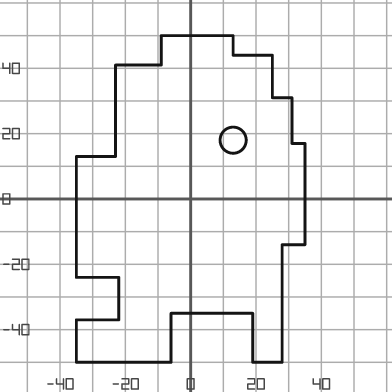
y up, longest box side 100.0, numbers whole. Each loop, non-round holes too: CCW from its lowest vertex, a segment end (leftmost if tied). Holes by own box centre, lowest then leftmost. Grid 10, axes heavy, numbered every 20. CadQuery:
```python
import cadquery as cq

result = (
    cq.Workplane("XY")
    .moveTo(-35.0, -50.0)
    .lineTo(-6.0, -50.0)
    .lineTo(-6.0, -35.0)
    .lineTo(19.0, -35.0)
    .lineTo(19.0, -50.0)
    .lineTo(28.0, -50.0)
    .lineTo(28.0, -14.0)
    .lineTo(35.0, -14.0)
    .lineTo(35.0, 17.0)
    .lineTo(31.0, 17.0)
    .lineTo(31.0, 31.0)
    .lineTo(25.0, 31.0)
    .lineTo(25.0, 44.0)
    .lineTo(13.0, 44.0)
    .lineTo(13.0, 50.0)
    .lineTo(-9.0, 50.0)
    .lineTo(-9.0, 41.0)
    .lineTo(-23.0, 41.0)
    .lineTo(-23.0, 13.0)
    .lineTo(-35.0, 13.0)
    .lineTo(-35.0, -24.0)
    .lineTo(-22.0, -24.0)
    .lineTo(-22.0, -37.0)
    .lineTo(-35.0, -37.0)
    .close()
    .moveTo(13.0, 18.0)
    .circle(4.0)
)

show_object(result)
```